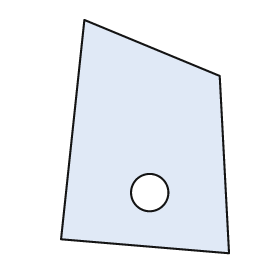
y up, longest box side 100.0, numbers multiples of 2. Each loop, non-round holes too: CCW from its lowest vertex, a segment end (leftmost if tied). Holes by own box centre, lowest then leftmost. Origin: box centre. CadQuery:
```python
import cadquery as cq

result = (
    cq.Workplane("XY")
    .moveTo(36.0, -50.0)
    .lineTo(32.0, 26.0)
    .lineTo(-26.0, 50.0)
    .lineTo(-36.0, -44.0)
    .close()
    .moveTo(2.0, -24.0)
    .circle(8.0)
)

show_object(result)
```